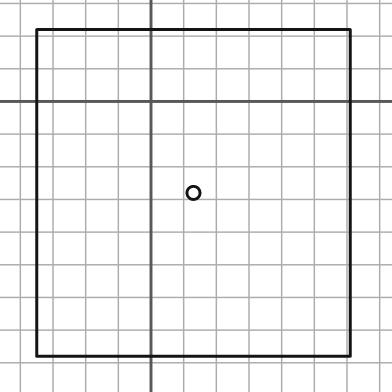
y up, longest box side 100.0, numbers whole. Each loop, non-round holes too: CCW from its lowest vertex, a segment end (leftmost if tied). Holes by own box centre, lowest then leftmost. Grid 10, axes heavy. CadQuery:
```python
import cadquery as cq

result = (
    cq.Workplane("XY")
    .moveTo(-35.0, -78.0)
    .lineTo(61.0, -78.0)
    .lineTo(61.0, 22.0)
    .lineTo(-35.0, 22.0)
    .close()
    .moveTo(13.0, -28.0)
    .circle(2.0)
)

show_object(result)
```